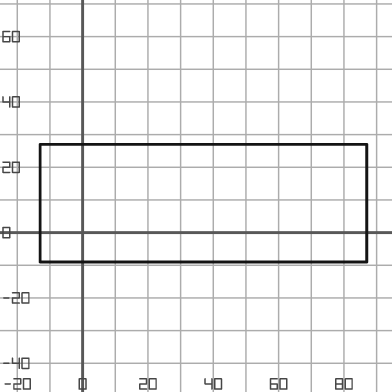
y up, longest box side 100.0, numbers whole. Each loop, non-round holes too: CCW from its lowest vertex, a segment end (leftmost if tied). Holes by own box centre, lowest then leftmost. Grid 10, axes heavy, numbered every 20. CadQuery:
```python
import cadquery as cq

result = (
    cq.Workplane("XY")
    .moveTo(-13.0, -9.0)
    .lineTo(87.0, -9.0)
    .lineTo(87.0, 27.0)
    .lineTo(-13.0, 27.0)
    .close()
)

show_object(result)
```